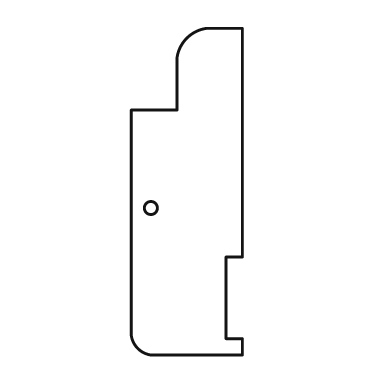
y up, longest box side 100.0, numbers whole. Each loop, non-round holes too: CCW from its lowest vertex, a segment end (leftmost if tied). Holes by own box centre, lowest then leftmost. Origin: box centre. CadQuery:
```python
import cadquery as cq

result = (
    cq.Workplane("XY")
    .moveTo(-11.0, -50.0)
    .lineTo(17.0, -50.0)
    .lineTo(17.0, -45.0)
    .lineTo(12.0, -45.0)
    .lineTo(12.0, -20.0)
    .lineTo(17.0, -20.0)
    .lineTo(17.0, 50.0)
    .lineTo(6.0, 50.0)
    .threePointArc((0.0, 47.0), (-3.0, 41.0))
    .lineTo(-3.0, 25.0)
    .lineTo(-17.0, 25.0)
    .lineTo(-17.0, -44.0)
    .threePointArc((-15.0, -48.0), (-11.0, -50.0))
    .close()
    .moveTo(-11.0, -5.0)
    .circle(2.0)
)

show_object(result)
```